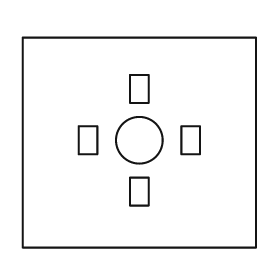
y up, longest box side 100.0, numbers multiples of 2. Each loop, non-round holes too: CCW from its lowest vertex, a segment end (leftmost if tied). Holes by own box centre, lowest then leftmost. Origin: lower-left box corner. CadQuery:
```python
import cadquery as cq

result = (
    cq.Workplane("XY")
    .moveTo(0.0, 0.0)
    .lineTo(100.0, 0.0)
    .lineTo(100.0, 90.0)
    .lineTo(0.0, 90.0)
    .close()
    .moveTo(46.0, 18.0)
    .lineTo(54.0, 18.0)
    .lineTo(54.0, 30.0)
    .lineTo(46.0, 30.0)
    .close()
    .moveTo(24.0, 40.0)
    .lineTo(32.0, 40.0)
    .lineTo(32.0, 52.0)
    .lineTo(24.0, 52.0)
    .close()
    .moveTo(50.0, 46.0)
    .circle(10.0)
    .moveTo(68.0, 40.0)
    .lineTo(76.0, 40.0)
    .lineTo(76.0, 52.0)
    .lineTo(68.0, 52.0)
    .close()
    .moveTo(46.0, 62.0)
    .lineTo(54.0, 62.0)
    .lineTo(54.0, 74.0)
    .lineTo(46.0, 74.0)
    .close()
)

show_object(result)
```